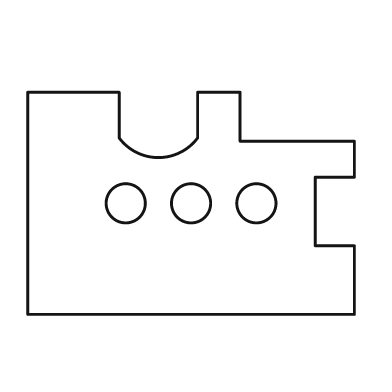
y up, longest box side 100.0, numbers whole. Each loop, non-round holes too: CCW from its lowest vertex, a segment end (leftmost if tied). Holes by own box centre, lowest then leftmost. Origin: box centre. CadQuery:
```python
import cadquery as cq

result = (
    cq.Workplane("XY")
    .moveTo(-50.0, -34.0)
    .lineTo(50.0, -34.0)
    .lineTo(50.0, -13.0)
    .lineTo(38.0, -13.0)
    .lineTo(38.0, 8.0)
    .lineTo(50.0, 8.0)
    .lineTo(50.0, 19.0)
    .lineTo(15.0, 19.0)
    .lineTo(15.0, 34.0)
    .lineTo(2.0, 34.0)
    .lineTo(2.0, 20.0)
    .threePointArc((-10.0, 14.0), (-22.0, 20.0))
    .lineTo(-22.0, 34.0)
    .lineTo(-50.0, 34.0)
    .close()
    .moveTo(-20.0, 0.0)
    .circle(6.0)
    .moveTo(0.0, 0.0)
    .circle(6.0)
    .moveTo(20.0, 0.0)
    .circle(6.0)
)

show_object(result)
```